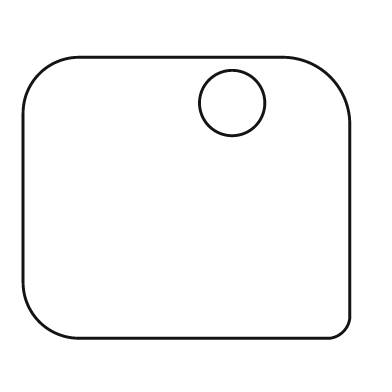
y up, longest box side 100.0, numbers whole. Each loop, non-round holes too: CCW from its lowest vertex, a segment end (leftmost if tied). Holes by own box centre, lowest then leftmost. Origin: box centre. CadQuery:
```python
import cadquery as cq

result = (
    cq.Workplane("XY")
    .moveTo(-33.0, -43.0)
    .lineTo(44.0, -43.0)
    .threePointArc((48.0, -41.0), (50.0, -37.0))
    .lineTo(50.0, 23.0)
    .threePointArc((44.0, 37.0), (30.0, 43.0))
    .lineTo(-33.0, 43.0)
    .threePointArc((-45.0, 38.0), (-50.0, 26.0))
    .lineTo(-50.0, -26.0)
    .threePointArc((-45.0, -38.0), (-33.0, -43.0))
    .close()
    .moveTo(14.0, 29.0)
    .circle(10.0)
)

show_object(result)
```